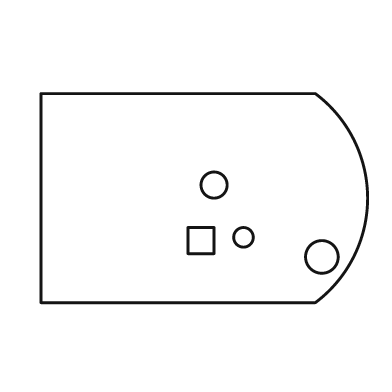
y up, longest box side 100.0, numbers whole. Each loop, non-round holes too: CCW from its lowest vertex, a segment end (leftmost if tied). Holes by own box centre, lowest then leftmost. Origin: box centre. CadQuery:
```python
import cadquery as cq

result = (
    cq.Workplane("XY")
    .moveTo(-50.0, -32.0)
    .lineTo(34.0, -32.0)
    .threePointArc((50.0, 0.0), (34.0, 32.0))
    .lineTo(-50.0, 32.0)
    .close()
    .moveTo(36.0, -18.0)
    .circle(5.0)
    .moveTo(-5.0, -17.0)
    .lineTo(3.0, -17.0)
    .lineTo(3.0, -9.0)
    .lineTo(-5.0, -9.0)
    .close()
    .moveTo(12.0, -12.0)
    .circle(3.0)
    .moveTo(3.0, 4.0)
    .circle(4.0)
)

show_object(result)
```